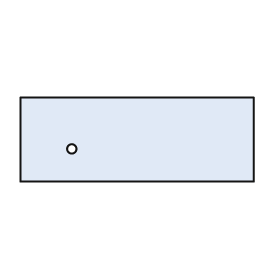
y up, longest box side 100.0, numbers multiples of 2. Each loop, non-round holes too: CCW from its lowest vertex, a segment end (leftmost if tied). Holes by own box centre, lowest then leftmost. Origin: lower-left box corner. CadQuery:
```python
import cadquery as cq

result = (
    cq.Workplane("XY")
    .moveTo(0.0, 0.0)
    .lineTo(100.0, 0.0)
    .lineTo(100.0, 36.0)
    .lineTo(0.0, 36.0)
    .close()
    .moveTo(22.0, 14.0)
    .circle(2.0)
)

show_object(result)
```